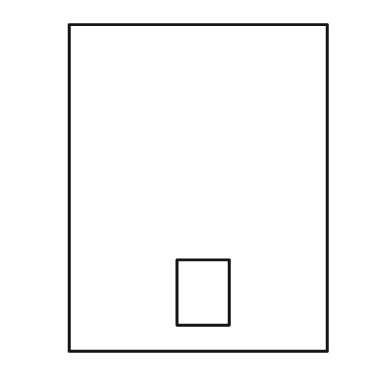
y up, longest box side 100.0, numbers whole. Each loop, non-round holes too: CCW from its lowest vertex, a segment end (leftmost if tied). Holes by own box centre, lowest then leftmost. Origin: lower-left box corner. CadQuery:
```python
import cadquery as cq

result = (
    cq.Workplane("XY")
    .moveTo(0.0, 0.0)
    .lineTo(79.0, 0.0)
    .lineTo(79.0, 100.0)
    .lineTo(0.0, 100.0)
    .close()
    .moveTo(33.0, 8.0)
    .lineTo(49.0, 8.0)
    .lineTo(49.0, 28.0)
    .lineTo(33.0, 28.0)
    .close()
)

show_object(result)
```